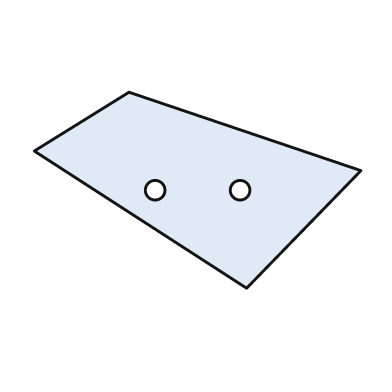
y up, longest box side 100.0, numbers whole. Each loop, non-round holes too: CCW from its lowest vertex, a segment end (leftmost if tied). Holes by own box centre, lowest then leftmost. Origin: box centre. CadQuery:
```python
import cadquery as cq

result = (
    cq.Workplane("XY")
    .moveTo(15.0, -30.0)
    .lineTo(50.0, 6.0)
    .lineTo(-21.0, 30.0)
    .lineTo(-50.0, 12.0)
    .close()
    .moveTo(-13.0, 0.0)
    .circle(3.0)
    .moveTo(13.0, 0.0)
    .circle(3.0)
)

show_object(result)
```